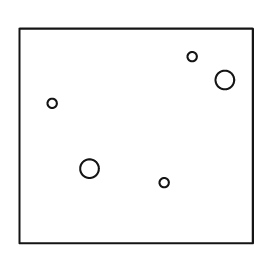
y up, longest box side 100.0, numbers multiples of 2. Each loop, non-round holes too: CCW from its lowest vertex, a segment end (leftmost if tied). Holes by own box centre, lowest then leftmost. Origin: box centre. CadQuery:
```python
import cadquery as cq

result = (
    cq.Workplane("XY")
    .moveTo(-50.0, -46.0)
    .lineTo(50.0, -46.0)
    .lineTo(50.0, 46.0)
    .lineTo(-50.0, 46.0)
    .close()
    .moveTo(12.0, -20.0)
    .circle(2.0)
    .moveTo(-20.0, -14.0)
    .circle(4.0)
    .moveTo(-36.0, 14.0)
    .circle(2.0)
    .moveTo(38.0, 24.0)
    .circle(4.0)
    .moveTo(24.0, 34.0)
    .circle(2.0)
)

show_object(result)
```